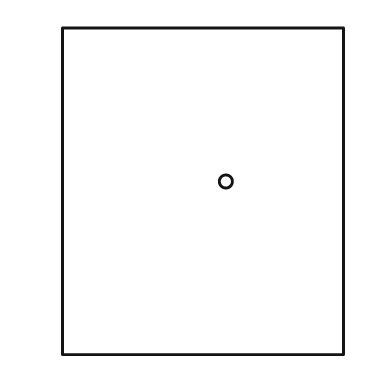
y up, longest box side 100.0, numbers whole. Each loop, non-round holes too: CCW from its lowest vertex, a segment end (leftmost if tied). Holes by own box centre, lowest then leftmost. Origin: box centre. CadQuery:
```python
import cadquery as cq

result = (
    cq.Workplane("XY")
    .moveTo(-43.0, -50.0)
    .lineTo(43.0, -50.0)
    .lineTo(43.0, 50.0)
    .lineTo(-43.0, 50.0)
    .close()
    .moveTo(7.0, 3.0)
    .circle(2.0)
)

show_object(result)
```